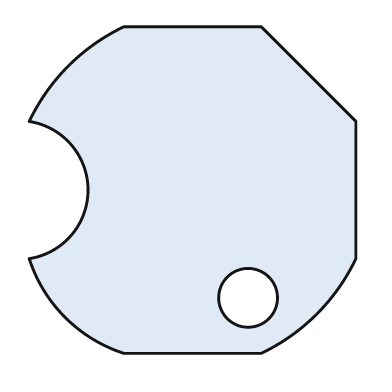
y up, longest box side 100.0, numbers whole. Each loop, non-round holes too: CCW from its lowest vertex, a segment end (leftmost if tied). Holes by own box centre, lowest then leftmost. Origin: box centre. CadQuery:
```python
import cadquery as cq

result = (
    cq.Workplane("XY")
    .moveTo(-21.0, -50.0)
    .lineTo(21.0, -50.0)
    .threePointArc((38.0, -38.0), (50.0, -21.0))
    .lineTo(50.0, 21.0)
    .lineTo(21.0, 50.0)
    .lineTo(-21.0, 50.0)
    .threePointArc((-38.0, 38.0), (-50.0, 21.0))
    .threePointArc((-32.0, 0.0), (-50.0, -21.0))
    .threePointArc((-39.0, -39.0), (-21.0, -50.0))
    .close()
    .moveTo(17.0, -33.0)
    .circle(9.0)
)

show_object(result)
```